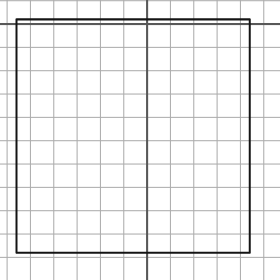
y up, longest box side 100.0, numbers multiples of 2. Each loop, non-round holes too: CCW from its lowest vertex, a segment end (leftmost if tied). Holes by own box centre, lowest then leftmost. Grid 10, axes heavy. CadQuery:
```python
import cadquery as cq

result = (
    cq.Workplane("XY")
    .moveTo(-56.0, -98.0)
    .lineTo(44.0, -98.0)
    .lineTo(44.0, 2.0)
    .lineTo(-56.0, 2.0)
    .close()
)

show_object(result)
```